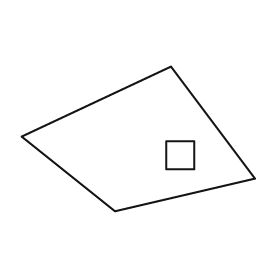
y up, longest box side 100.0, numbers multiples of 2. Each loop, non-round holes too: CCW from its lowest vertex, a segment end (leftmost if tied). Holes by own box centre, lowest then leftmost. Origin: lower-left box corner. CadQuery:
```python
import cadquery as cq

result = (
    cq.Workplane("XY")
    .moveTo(40.0, 0.0)
    .lineTo(100.0, 14.0)
    .lineTo(64.0, 62.0)
    .lineTo(0.0, 32.0)
    .close()
    .moveTo(62.0, 18.0)
    .lineTo(74.0, 18.0)
    .lineTo(74.0, 30.0)
    .lineTo(62.0, 30.0)
    .close()
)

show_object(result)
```